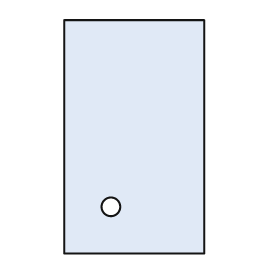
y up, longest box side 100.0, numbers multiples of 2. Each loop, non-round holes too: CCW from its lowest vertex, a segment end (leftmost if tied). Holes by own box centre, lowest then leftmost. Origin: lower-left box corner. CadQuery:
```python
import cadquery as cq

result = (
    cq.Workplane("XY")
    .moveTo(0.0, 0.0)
    .lineTo(60.0, 0.0)
    .lineTo(60.0, 100.0)
    .lineTo(0.0, 100.0)
    .close()
    .moveTo(20.0, 20.0)
    .circle(4.0)
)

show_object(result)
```